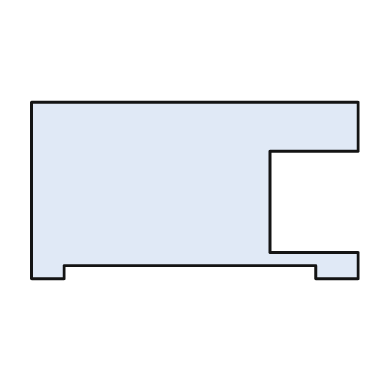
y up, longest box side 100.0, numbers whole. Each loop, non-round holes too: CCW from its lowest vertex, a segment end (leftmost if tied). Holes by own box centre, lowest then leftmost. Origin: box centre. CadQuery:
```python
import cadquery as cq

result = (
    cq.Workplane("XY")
    .moveTo(-50.0, -27.0)
    .lineTo(-40.0, -27.0)
    .lineTo(-40.0, -23.0)
    .lineTo(37.0, -23.0)
    .lineTo(37.0, -27.0)
    .lineTo(50.0, -27.0)
    .lineTo(50.0, -19.0)
    .lineTo(23.0, -19.0)
    .lineTo(23.0, 12.0)
    .lineTo(50.0, 12.0)
    .lineTo(50.0, 27.0)
    .lineTo(-50.0, 27.0)
    .close()
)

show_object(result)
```